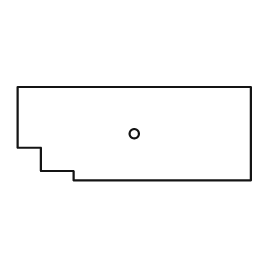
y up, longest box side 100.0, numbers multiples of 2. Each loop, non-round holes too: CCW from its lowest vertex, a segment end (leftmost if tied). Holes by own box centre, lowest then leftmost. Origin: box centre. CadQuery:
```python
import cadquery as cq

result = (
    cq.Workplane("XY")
    .moveTo(-26.0, -20.0)
    .lineTo(50.0, -20.0)
    .lineTo(50.0, 20.0)
    .lineTo(-50.0, 20.0)
    .lineTo(-50.0, -6.0)
    .lineTo(-40.0, -6.0)
    .lineTo(-40.0, -16.0)
    .lineTo(-26.0, -16.0)
    .close()
    .moveTo(0.0, 0.0)
    .circle(2.0)
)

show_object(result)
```